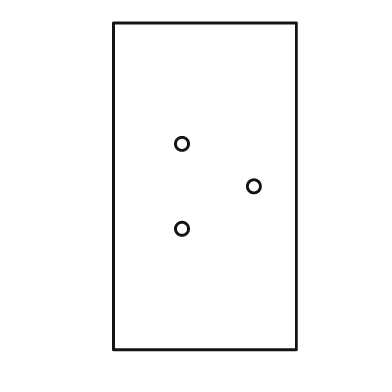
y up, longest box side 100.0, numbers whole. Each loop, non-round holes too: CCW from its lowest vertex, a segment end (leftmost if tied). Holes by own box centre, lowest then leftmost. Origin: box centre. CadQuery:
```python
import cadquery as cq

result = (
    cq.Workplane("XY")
    .moveTo(-28.0, -50.0)
    .lineTo(28.0, -50.0)
    .lineTo(28.0, 50.0)
    .lineTo(-28.0, 50.0)
    .close()
    .moveTo(-7.0, -13.0)
    .circle(2.0)
    .moveTo(15.0, 0.0)
    .circle(2.0)
    .moveTo(-7.0, 13.0)
    .circle(2.0)
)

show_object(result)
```